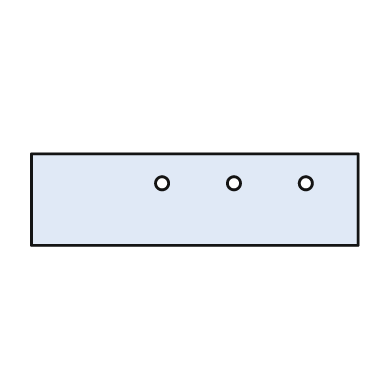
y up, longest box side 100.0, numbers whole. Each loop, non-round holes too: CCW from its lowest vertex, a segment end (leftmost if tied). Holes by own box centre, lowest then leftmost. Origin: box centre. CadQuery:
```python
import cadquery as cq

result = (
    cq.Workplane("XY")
    .moveTo(-50.0, -14.0)
    .lineTo(50.0, -14.0)
    .lineTo(50.0, 14.0)
    .lineTo(-50.0, 14.0)
    .close()
    .moveTo(-10.0, 5.0)
    .circle(2.0)
    .moveTo(12.0, 5.0)
    .circle(2.0)
    .moveTo(34.0, 5.0)
    .circle(2.0)
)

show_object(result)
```